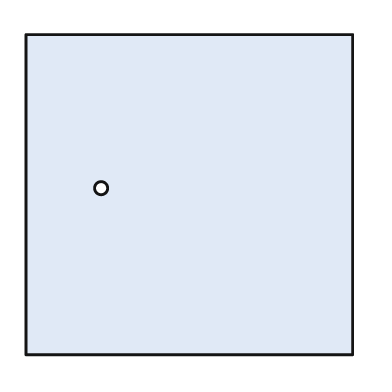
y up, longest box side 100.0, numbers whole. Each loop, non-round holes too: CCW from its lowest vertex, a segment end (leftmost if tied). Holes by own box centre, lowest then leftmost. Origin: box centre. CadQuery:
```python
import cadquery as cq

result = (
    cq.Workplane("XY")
    .moveTo(-50.0, -49.0)
    .lineTo(50.0, -49.0)
    .lineTo(50.0, 49.0)
    .lineTo(-50.0, 49.0)
    .close()
    .moveTo(-27.0, 2.0)
    .circle(2.0)
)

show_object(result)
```